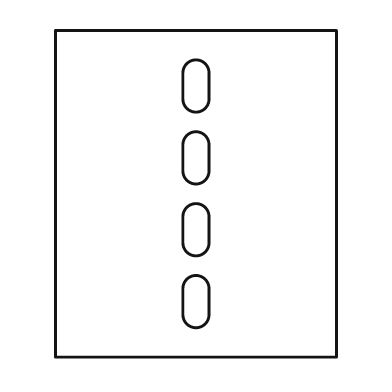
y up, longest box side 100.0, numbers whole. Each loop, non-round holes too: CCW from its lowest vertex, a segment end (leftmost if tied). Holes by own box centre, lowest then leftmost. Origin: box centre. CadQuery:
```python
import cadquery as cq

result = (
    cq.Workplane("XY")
    .moveTo(-43.0, -50.0)
    .lineTo(43.0, -50.0)
    .lineTo(43.0, 50.0)
    .lineTo(-43.0, 50.0)
    .close()
    .moveTo(-4.0, -37.0)
    .threePointArc((0.0, -41.0), (4.0, -37.0))
    .lineTo(4.0, -29.0)
    .threePointArc((0.0, -25.0), (-4.0, -29.0))
    .close()
    .moveTo(-4.0, -15.0)
    .threePointArc((0.0, -19.0), (4.0, -15.0))
    .lineTo(4.0, -7.0)
    .threePointArc((0.0, -3.0), (-4.0, -7.0))
    .close()
    .moveTo(-4.0, 7.0)
    .threePointArc((0.0, 3.0), (4.0, 7.0))
    .lineTo(4.0, 15.0)
    .threePointArc((0.0, 19.0), (-4.0, 15.0))
    .close()
    .moveTo(-4.0, 29.0)
    .threePointArc((0.0, 25.0), (4.0, 29.0))
    .lineTo(4.0, 37.0)
    .threePointArc((0.0, 41.0), (-4.0, 37.0))
    .close()
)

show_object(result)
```